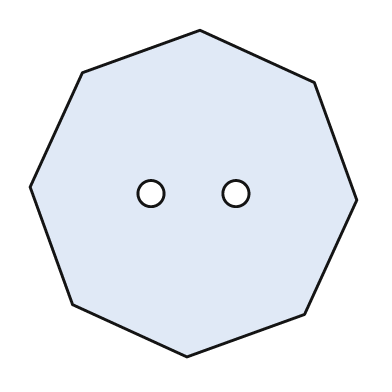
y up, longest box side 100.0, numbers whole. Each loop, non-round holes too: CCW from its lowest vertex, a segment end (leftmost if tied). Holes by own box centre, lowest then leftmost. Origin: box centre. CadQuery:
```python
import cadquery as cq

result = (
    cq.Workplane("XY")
    .moveTo(-2.0, -50.0)
    .lineTo(34.0, -37.0)
    .lineTo(50.0, -2.0)
    .lineTo(37.0, 34.0)
    .lineTo(2.0, 50.0)
    .lineTo(-34.0, 37.0)
    .lineTo(-50.0, 2.0)
    .lineTo(-37.0, -34.0)
    .close()
    .moveTo(-13.0, 0.0)
    .circle(4.0)
    .moveTo(13.0, 0.0)
    .circle(4.0)
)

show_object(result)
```